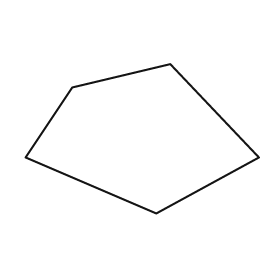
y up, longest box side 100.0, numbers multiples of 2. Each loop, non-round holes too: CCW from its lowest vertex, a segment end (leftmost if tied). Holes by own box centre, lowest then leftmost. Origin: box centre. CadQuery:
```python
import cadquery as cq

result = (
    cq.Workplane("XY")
    .moveTo(6.0, -32.0)
    .lineTo(50.0, -8.0)
    .lineTo(12.0, 32.0)
    .lineTo(-30.0, 22.0)
    .lineTo(-50.0, -8.0)
    .close()
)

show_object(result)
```